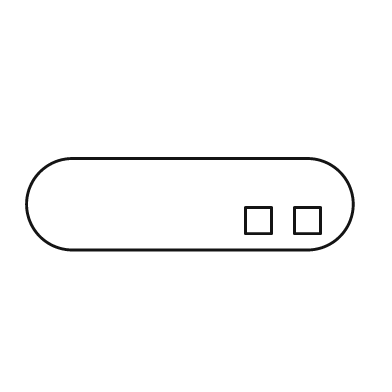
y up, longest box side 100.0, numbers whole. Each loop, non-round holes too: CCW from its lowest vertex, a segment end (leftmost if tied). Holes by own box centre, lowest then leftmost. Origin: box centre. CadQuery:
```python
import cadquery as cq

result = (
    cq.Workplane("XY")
    .moveTo(-36.0, -14.0)
    .lineTo(36.0, -14.0)
    .threePointArc((50.0, 0.0), (36.0, 14.0))
    .lineTo(-36.0, 14.0)
    .threePointArc((-50.0, 0.0), (-36.0, -14.0))
    .close()
    .moveTo(17.0, -9.0)
    .lineTo(25.0, -9.0)
    .lineTo(25.0, -1.0)
    .lineTo(17.0, -1.0)
    .close()
    .moveTo(32.0, -9.0)
    .lineTo(40.0, -9.0)
    .lineTo(40.0, -1.0)
    .lineTo(32.0, -1.0)
    .close()
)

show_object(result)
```